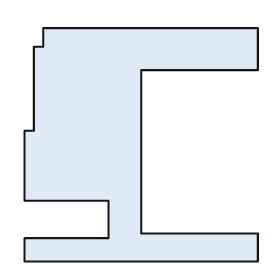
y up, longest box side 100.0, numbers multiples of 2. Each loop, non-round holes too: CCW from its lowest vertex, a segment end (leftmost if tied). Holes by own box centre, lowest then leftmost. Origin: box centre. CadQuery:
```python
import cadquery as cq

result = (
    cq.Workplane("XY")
    .moveTo(-50.0, -50.0)
    .lineTo(50.0, -50.0)
    .lineTo(50.0, -38.0)
    .lineTo(0.0, -38.0)
    .lineTo(0.0, 32.0)
    .lineTo(50.0, 32.0)
    .lineTo(50.0, 50.0)
    .lineTo(-42.0, 50.0)
    .lineTo(-42.0, 42.0)
    .lineTo(-46.0, 42.0)
    .lineTo(-46.0, 6.0)
    .lineTo(-50.0, 6.0)
    .lineTo(-50.0, -24.0)
    .lineTo(-14.0, -24.0)
    .lineTo(-14.0, -40.0)
    .lineTo(-50.0, -40.0)
    .close()
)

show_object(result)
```